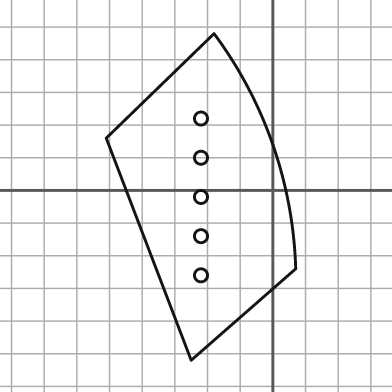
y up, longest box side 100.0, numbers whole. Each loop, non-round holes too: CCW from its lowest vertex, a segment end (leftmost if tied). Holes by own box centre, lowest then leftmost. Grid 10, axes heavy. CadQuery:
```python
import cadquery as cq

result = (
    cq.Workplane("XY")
    .moveTo(-25.0, -52.0)
    .lineTo(7.0, -24.0)
    .threePointArc((0.0, 14.0), (-18.0, 48.0))
    .lineTo(-51.0, 16.0)
    .close()
    .moveTo(-22.0, -26.0)
    .circle(2.0)
    .moveTo(-22.0, -14.0)
    .circle(2.0)
    .moveTo(-22.0, -2.0)
    .circle(2.0)
    .moveTo(-22.0, 10.0)
    .circle(2.0)
    .moveTo(-22.0, 22.0)
    .circle(2.0)
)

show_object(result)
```